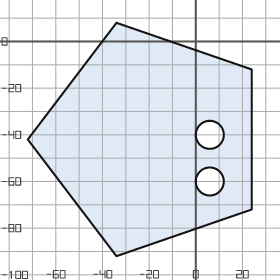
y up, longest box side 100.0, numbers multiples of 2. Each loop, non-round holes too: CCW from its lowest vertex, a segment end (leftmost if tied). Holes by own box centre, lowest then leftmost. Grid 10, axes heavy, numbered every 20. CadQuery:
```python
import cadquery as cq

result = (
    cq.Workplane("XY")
    .moveTo(-34.0, -92.0)
    .lineTo(24.0, -72.0)
    .lineTo(24.0, -12.0)
    .lineTo(-34.0, 8.0)
    .lineTo(-72.0, -42.0)
    .close()
    .moveTo(6.0, -60.0)
    .circle(6.0)
    .moveTo(6.0, -40.0)
    .circle(6.0)
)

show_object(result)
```